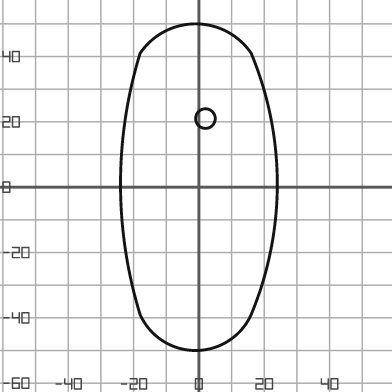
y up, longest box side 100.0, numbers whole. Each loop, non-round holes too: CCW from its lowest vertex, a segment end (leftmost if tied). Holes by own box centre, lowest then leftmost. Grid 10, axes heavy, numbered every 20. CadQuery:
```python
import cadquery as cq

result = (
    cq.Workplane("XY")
    .moveTo(-18.0, -39.0)
    .threePointArc((-1.0, -50.0), (16.0, -39.0))
    .threePointArc((24.0, 1.0), (16.0, 41.0))
    .threePointArc((-1.0, 50.0), (-18.0, 41.0))
    .threePointArc((-24.0, 1.0), (-18.0, -39.0))
    .close()
    .moveTo(2.0, 21.0)
    .circle(3.0)
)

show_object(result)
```